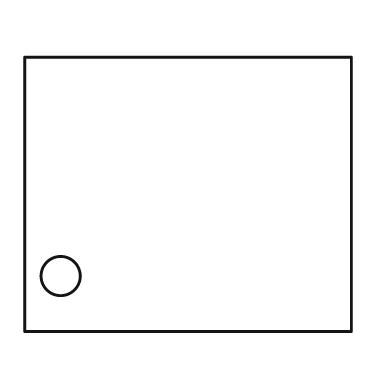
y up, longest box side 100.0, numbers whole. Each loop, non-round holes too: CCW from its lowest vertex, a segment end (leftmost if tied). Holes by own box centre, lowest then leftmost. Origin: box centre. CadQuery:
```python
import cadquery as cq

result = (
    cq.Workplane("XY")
    .moveTo(-50.0, -42.0)
    .lineTo(50.0, -42.0)
    .lineTo(50.0, 42.0)
    .lineTo(-50.0, 42.0)
    .close()
    .moveTo(-39.0, -25.0)
    .circle(6.0)
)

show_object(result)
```